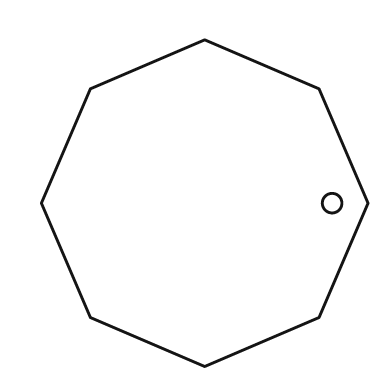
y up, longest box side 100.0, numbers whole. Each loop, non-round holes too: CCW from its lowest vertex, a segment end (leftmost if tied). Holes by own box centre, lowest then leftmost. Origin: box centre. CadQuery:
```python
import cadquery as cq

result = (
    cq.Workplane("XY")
    .moveTo(0.0, -50.0)
    .lineTo(35.0, -35.0)
    .lineTo(50.0, 0.0)
    .lineTo(35.0, 35.0)
    .lineTo(0.0, 50.0)
    .lineTo(-35.0, 35.0)
    .lineTo(-50.0, 0.0)
    .lineTo(-35.0, -35.0)
    .close()
    .moveTo(39.0, 0.0)
    .circle(3.0)
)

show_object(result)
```